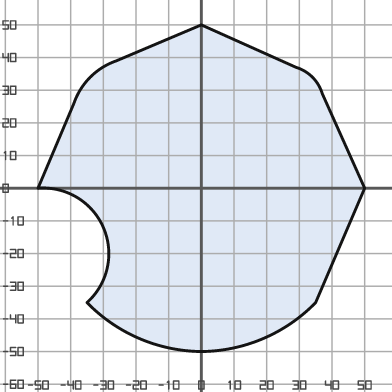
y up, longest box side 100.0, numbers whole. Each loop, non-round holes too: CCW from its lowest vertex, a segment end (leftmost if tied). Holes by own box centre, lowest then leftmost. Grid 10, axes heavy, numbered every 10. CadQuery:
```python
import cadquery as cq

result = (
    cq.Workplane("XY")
    .moveTo(0.0, -50.0)
    .threePointArc((19.0, -46.0), (35.0, -35.0))
    .lineTo(50.0, 0.0)
    .lineTo(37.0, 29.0)
    .threePointArc((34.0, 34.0), (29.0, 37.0))
    .lineTo(0.0, 50.0)
    .lineTo(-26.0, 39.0)
    .threePointArc((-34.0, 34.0), (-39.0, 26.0))
    .lineTo(-50.0, 0.0)
    .threePointArc((-30.0, -12.0), (-35.0, -35.0))
    .threePointArc((-19.0, -46.0), (0.0, -50.0))
    .close()
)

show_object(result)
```